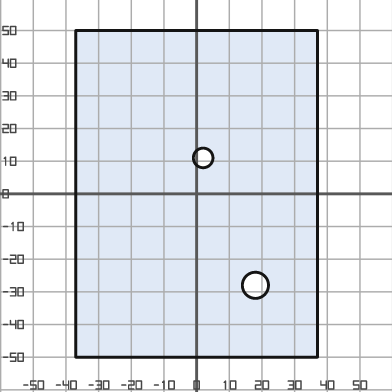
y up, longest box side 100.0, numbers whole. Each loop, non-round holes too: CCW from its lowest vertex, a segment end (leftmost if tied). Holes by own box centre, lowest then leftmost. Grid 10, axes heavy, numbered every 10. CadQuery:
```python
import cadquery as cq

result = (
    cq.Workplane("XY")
    .moveTo(-37.0, -50.0)
    .lineTo(37.0, -50.0)
    .lineTo(37.0, 50.0)
    .lineTo(-37.0, 50.0)
    .close()
    .moveTo(18.0, -28.0)
    .circle(4.0)
    .moveTo(2.0, 11.0)
    .circle(3.0)
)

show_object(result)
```